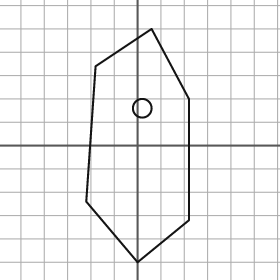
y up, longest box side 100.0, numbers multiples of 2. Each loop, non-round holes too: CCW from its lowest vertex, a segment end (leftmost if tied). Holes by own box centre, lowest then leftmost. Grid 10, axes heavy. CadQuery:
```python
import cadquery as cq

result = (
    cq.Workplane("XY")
    .moveTo(0.0, -50.0)
    .lineTo(22.0, -32.0)
    .lineTo(22.0, 20.0)
    .lineTo(6.0, 50.0)
    .lineTo(-18.0, 34.0)
    .lineTo(-22.0, -24.0)
    .close()
    .moveTo(2.0, 16.0)
    .circle(4.0)
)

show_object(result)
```